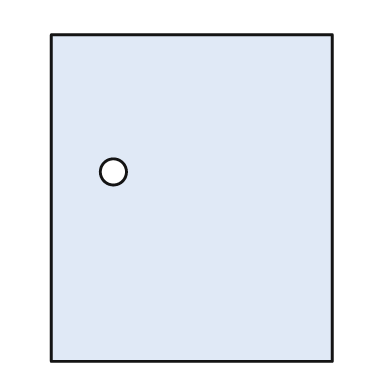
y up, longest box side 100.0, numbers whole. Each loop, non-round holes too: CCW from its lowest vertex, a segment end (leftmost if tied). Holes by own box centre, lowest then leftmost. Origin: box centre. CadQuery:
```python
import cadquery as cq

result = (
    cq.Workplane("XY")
    .moveTo(-43.0, -50.0)
    .lineTo(43.0, -50.0)
    .lineTo(43.0, 50.0)
    .lineTo(-43.0, 50.0)
    .close()
    .moveTo(-24.0, 8.0)
    .circle(4.0)
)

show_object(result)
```